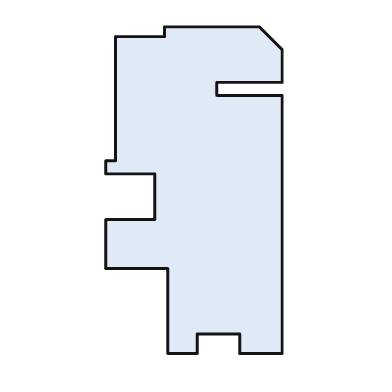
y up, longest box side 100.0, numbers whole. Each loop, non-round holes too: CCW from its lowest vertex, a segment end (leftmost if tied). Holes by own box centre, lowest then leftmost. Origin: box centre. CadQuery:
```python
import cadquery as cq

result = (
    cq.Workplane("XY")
    .moveTo(-8.0, -50.0)
    .lineTo(1.0, -50.0)
    .lineTo(1.0, -44.0)
    .lineTo(14.0, -44.0)
    .lineTo(14.0, -50.0)
    .lineTo(27.0, -50.0)
    .lineTo(27.0, 29.0)
    .lineTo(7.0, 29.0)
    .lineTo(7.0, 33.0)
    .lineTo(27.0, 33.0)
    .lineTo(27.0, 43.0)
    .lineTo(20.0, 50.0)
    .lineTo(-9.0, 50.0)
    .lineTo(-9.0, 47.0)
    .lineTo(-24.0, 47.0)
    .lineTo(-24.0, 9.0)
    .lineTo(-27.0, 9.0)
    .lineTo(-27.0, 5.0)
    .lineTo(-12.0, 5.0)
    .lineTo(-12.0, -9.0)
    .lineTo(-27.0, -9.0)
    .lineTo(-27.0, -24.0)
    .lineTo(-8.0, -24.0)
    .close()
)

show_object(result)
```